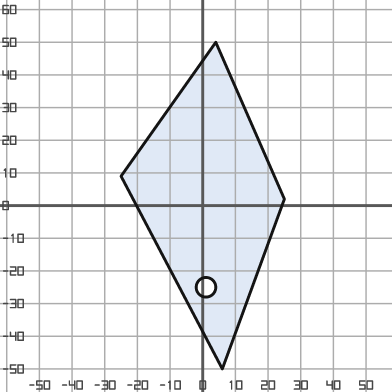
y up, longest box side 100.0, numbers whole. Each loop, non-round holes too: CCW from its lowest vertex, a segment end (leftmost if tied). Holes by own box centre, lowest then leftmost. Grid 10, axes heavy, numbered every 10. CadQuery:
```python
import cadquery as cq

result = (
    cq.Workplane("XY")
    .moveTo(6.0, -50.0)
    .lineTo(25.0, 2.0)
    .lineTo(4.0, 50.0)
    .lineTo(-25.0, 9.0)
    .close()
    .moveTo(1.0, -25.0)
    .circle(3.0)
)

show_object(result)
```